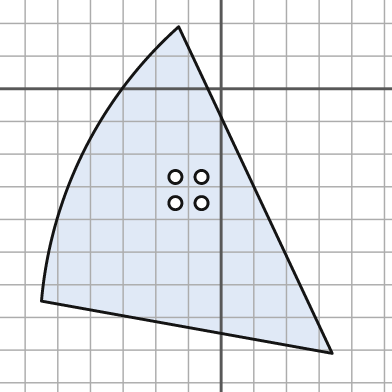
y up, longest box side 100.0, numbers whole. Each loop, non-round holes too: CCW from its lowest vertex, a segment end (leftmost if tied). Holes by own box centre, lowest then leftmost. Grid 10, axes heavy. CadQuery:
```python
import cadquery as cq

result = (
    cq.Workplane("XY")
    .moveTo(34.0, -81.0)
    .lineTo(-13.0, 19.0)
    .threePointArc((-42.0, -19.0), (-55.0, -65.0))
    .close()
    .moveTo(-14.0, -35.0)
    .circle(2.0)
    .moveTo(-6.0, -35.0)
    .circle(2.0)
    .moveTo(-14.0, -27.0)
    .circle(2.0)
    .moveTo(-6.0, -27.0)
    .circle(2.0)
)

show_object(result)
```